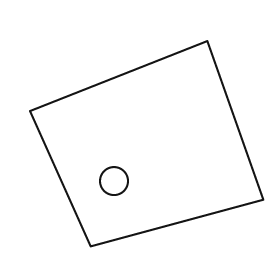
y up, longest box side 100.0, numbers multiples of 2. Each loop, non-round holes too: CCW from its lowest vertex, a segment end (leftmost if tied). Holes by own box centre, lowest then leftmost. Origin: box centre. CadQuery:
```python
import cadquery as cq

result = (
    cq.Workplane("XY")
    .moveTo(-24.0, -44.0)
    .lineTo(50.0, -24.0)
    .lineTo(26.0, 44.0)
    .lineTo(-50.0, 14.0)
    .close()
    .moveTo(-14.0, -16.0)
    .circle(6.0)
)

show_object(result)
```